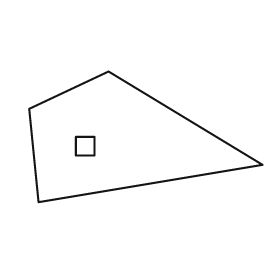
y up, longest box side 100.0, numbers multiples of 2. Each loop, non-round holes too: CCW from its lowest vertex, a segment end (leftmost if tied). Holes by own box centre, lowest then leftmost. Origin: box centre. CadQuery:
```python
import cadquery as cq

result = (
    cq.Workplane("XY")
    .moveTo(-46.0, -28.0)
    .lineTo(50.0, -12.0)
    .lineTo(-16.0, 28.0)
    .lineTo(-50.0, 12.0)
    .close()
    .moveTo(-30.0, -8.0)
    .lineTo(-22.0, -8.0)
    .lineTo(-22.0, 0.0)
    .lineTo(-30.0, 0.0)
    .close()
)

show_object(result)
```